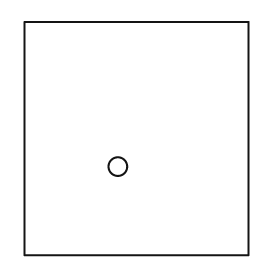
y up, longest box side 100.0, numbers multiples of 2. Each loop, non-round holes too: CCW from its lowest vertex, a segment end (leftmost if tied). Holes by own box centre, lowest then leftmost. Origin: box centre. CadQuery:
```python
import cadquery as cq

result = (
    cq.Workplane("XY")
    .moveTo(-48.0, -50.0)
    .lineTo(48.0, -50.0)
    .lineTo(48.0, 50.0)
    .lineTo(-48.0, 50.0)
    .close()
    .moveTo(-8.0, -12.0)
    .circle(4.0)
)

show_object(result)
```